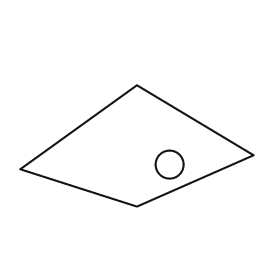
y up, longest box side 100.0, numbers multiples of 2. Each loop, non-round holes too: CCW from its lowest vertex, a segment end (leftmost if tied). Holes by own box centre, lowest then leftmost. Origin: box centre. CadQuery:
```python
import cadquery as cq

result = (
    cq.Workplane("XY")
    .moveTo(0.0, -26.0)
    .lineTo(50.0, -4.0)
    .lineTo(0.0, 26.0)
    .lineTo(-50.0, -10.0)
    .close()
    .moveTo(14.0, -8.0)
    .circle(6.0)
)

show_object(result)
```